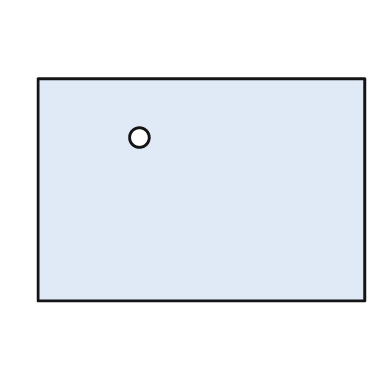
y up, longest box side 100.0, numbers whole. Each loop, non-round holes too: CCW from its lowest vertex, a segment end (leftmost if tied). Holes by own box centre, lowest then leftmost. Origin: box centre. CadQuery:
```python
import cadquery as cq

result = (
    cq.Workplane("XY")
    .moveTo(-50.0, -34.0)
    .lineTo(50.0, -34.0)
    .lineTo(50.0, 34.0)
    .lineTo(-50.0, 34.0)
    .close()
    .moveTo(-19.0, 16.0)
    .circle(3.0)
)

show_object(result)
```